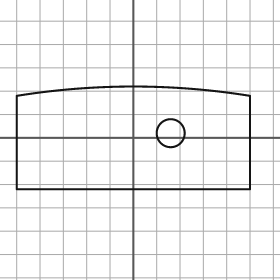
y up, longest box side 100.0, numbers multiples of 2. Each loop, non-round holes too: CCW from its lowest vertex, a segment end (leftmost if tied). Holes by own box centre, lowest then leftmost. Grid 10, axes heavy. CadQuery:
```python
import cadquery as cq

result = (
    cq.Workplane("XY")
    .moveTo(-50.0, -22.0)
    .lineTo(50.0, -22.0)
    .lineTo(50.0, 18.0)
    .threePointArc((0.0, 22.0), (-50.0, 18.0))
    .close()
    .moveTo(16.0, 2.0)
    .circle(6.0)
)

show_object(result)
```